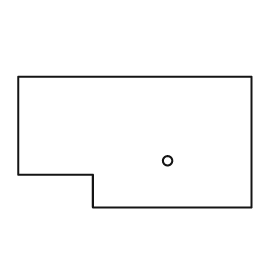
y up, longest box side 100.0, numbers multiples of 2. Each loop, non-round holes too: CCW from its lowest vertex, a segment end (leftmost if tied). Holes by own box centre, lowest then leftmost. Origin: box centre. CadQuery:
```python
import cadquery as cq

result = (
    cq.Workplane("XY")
    .moveTo(-18.0, -28.0)
    .lineTo(50.0, -28.0)
    .lineTo(50.0, 28.0)
    .lineTo(-50.0, 28.0)
    .lineTo(-50.0, -14.0)
    .lineTo(-18.0, -14.0)
    .close()
    .moveTo(14.0, -8.0)
    .circle(2.0)
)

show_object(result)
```